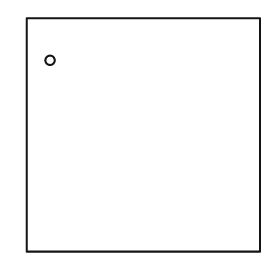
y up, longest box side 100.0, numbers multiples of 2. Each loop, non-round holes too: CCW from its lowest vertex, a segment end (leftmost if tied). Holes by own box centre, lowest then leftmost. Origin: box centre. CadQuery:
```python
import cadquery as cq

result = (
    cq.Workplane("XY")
    .moveTo(-50.0, -50.0)
    .lineTo(50.0, -50.0)
    .lineTo(50.0, 50.0)
    .lineTo(-50.0, 50.0)
    .close()
    .moveTo(-40.0, 32.0)
    .circle(2.0)
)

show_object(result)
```